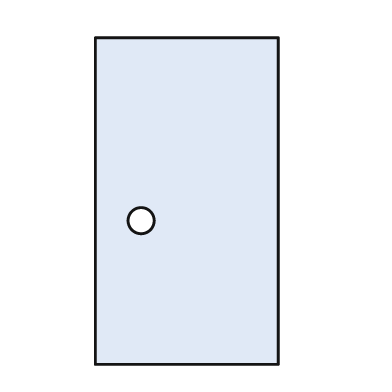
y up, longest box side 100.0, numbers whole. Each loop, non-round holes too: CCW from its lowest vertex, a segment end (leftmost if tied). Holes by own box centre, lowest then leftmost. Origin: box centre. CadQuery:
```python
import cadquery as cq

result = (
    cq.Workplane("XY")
    .moveTo(-28.0, -50.0)
    .lineTo(28.0, -50.0)
    .lineTo(28.0, 50.0)
    .lineTo(-28.0, 50.0)
    .close()
    .moveTo(-14.0, -6.0)
    .circle(4.0)
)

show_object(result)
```